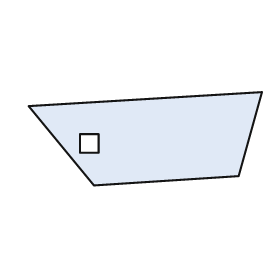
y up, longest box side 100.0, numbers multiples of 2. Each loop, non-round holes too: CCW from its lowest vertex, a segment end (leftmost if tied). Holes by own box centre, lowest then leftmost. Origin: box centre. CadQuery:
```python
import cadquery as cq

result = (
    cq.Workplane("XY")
    .moveTo(-22.0, -20.0)
    .lineTo(40.0, -16.0)
    .lineTo(50.0, 20.0)
    .lineTo(-50.0, 14.0)
    .close()
    .moveTo(-28.0, -6.0)
    .lineTo(-20.0, -6.0)
    .lineTo(-20.0, 2.0)
    .lineTo(-28.0, 2.0)
    .close()
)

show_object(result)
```